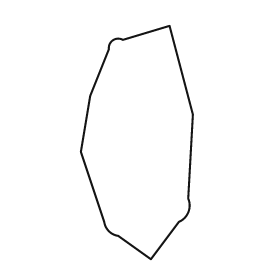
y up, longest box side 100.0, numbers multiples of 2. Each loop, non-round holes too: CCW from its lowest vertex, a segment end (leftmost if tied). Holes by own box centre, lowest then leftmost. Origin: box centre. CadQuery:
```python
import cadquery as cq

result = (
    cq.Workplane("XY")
    .moveTo(6.0, -50.0)
    .lineTo(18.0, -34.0)
    .threePointArc((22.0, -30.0), (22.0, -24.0))
    .lineTo(24.0, 12.0)
    .lineTo(14.0, 50.0)
    .lineTo(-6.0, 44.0)
    .threePointArc((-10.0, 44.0), (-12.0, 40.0))
    .lineTo(-20.0, 20.0)
    .lineTo(-24.0, -4.0)
    .lineTo(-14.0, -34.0)
    .threePointArc((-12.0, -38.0), (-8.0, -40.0))
    .close()
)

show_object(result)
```